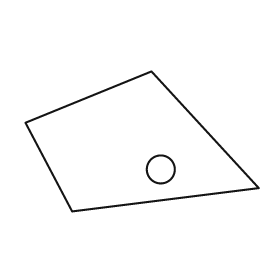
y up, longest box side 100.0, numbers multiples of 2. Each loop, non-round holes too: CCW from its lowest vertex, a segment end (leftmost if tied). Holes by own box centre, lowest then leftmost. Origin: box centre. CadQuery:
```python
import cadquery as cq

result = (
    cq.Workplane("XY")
    .moveTo(-30.0, -30.0)
    .lineTo(50.0, -20.0)
    .lineTo(4.0, 30.0)
    .lineTo(-50.0, 8.0)
    .close()
    .moveTo(8.0, -12.0)
    .circle(6.0)
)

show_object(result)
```